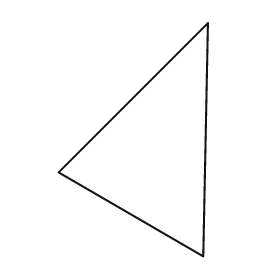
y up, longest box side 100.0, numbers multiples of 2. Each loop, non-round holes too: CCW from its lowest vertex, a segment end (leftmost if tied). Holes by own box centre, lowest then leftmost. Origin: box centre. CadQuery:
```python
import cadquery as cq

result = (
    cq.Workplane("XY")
    .moveTo(30.0, -50.0)
    .lineTo(32.0, 50.0)
    .lineTo(-32.0, -14.0)
    .close()
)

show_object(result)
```